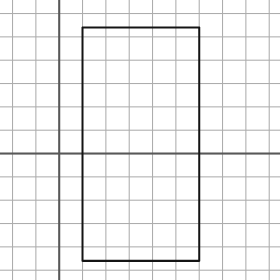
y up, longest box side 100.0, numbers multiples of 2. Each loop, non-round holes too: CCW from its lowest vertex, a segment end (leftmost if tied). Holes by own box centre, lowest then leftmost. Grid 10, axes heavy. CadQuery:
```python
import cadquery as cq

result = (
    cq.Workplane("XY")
    .moveTo(10.0, -46.0)
    .lineTo(60.0, -46.0)
    .lineTo(60.0, 54.0)
    .lineTo(10.0, 54.0)
    .close()
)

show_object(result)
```